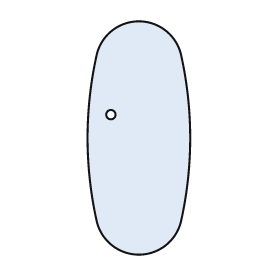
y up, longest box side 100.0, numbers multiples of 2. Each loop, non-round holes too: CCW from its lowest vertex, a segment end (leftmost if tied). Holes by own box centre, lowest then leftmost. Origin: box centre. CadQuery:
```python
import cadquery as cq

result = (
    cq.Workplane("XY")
    .moveTo(-18.0, -36.0)
    .threePointArc((0.0, -50.0), (18.0, -36.0))
    .threePointArc((22.0, 0.0), (18.0, 36.0))
    .threePointArc((0.0, 50.0), (-18.0, 36.0))
    .threePointArc((-22.0, 0.0), (-18.0, -36.0))
    .close()
    .moveTo(-12.0, 10.0)
    .circle(2.0)
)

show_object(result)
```